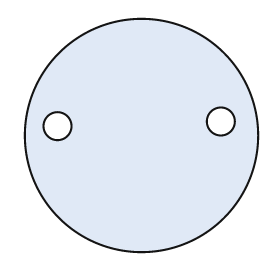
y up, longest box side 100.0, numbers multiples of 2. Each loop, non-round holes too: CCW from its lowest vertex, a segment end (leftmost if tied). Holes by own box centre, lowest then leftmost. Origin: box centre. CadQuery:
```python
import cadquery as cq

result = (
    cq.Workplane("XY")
    .moveTo(0.0, 0.0)
    .circle(50.0)
    .moveTo(-36.0, 4.0)
    .circle(6.0)
    .moveTo(34.0, 6.0)
    .circle(6.0)
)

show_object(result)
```